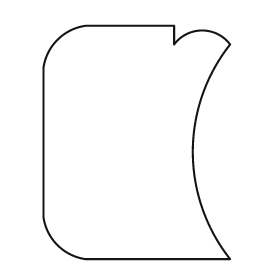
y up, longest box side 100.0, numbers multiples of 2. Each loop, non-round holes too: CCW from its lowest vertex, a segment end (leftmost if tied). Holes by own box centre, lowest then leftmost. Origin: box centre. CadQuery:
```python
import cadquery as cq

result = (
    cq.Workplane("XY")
    .moveTo(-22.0, -50.0)
    .lineTo(40.0, -50.0)
    .threePointArc((24.0, -4.0), (40.0, 42.0))
    .threePointArc((28.0, 48.0), (16.0, 42.0))
    .lineTo(16.0, 50.0)
    .lineTo(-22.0, 50.0)
    .threePointArc((-34.0, 44.0), (-40.0, 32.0))
    .lineTo(-40.0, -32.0)
    .threePointArc((-34.0, -44.0), (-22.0, -50.0))
    .close()
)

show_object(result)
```